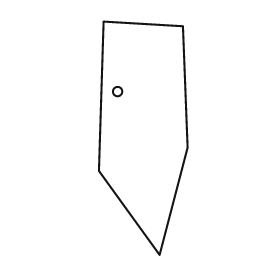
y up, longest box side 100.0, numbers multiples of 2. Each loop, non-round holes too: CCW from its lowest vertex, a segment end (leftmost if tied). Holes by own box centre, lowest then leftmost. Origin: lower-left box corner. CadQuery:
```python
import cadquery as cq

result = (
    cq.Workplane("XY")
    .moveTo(26.0, 0.0)
    .lineTo(38.0, 46.0)
    .lineTo(36.0, 98.0)
    .lineTo(2.0, 100.0)
    .lineTo(0.0, 36.0)
    .close()
    .moveTo(8.0, 70.0)
    .circle(2.0)
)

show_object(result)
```